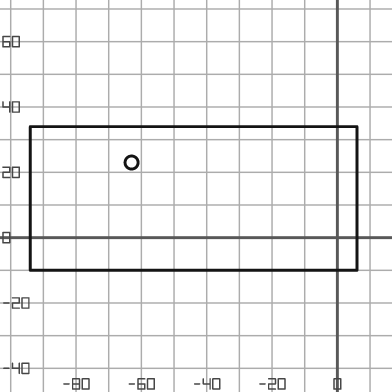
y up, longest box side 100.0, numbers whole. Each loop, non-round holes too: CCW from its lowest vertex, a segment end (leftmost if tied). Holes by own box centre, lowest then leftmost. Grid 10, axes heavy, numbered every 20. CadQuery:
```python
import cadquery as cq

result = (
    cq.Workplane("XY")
    .moveTo(-94.0, -10.0)
    .lineTo(6.0, -10.0)
    .lineTo(6.0, 34.0)
    .lineTo(-94.0, 34.0)
    .close()
    .moveTo(-63.0, 23.0)
    .circle(2.0)
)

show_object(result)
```